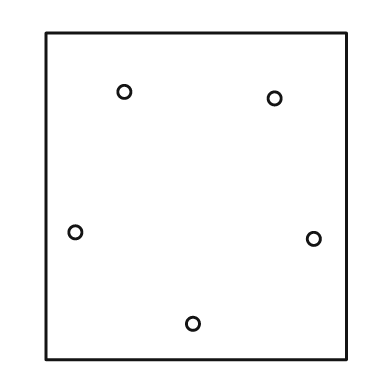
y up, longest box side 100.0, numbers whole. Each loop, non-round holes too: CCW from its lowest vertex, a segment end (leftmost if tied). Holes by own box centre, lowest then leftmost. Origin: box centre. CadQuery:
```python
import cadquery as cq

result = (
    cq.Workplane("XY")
    .moveTo(-46.0, -50.0)
    .lineTo(46.0, -50.0)
    .lineTo(46.0, 50.0)
    .lineTo(-46.0, 50.0)
    .close()
    .moveTo(-1.0, -39.0)
    .circle(2.0)
    .moveTo(36.0, -13.0)
    .circle(2.0)
    .moveTo(-37.0, -11.0)
    .circle(2.0)
    .moveTo(24.0, 30.0)
    .circle(2.0)
    .moveTo(-22.0, 32.0)
    .circle(2.0)
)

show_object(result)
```